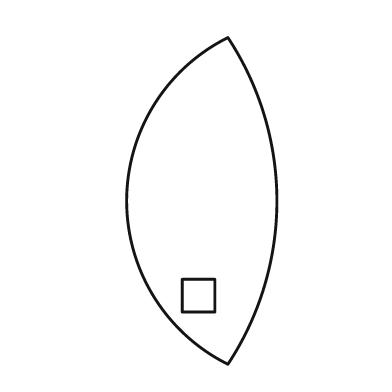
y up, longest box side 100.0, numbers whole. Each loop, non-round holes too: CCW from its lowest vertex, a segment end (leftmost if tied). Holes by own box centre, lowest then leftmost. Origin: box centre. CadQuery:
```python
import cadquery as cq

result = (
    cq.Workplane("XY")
    .moveTo(8.0, -50.0)
    .threePointArc((23.0, 0.0), (8.0, 50.0))
    .threePointArc((-23.0, 0.0), (8.0, -50.0))
    .close()
    .moveTo(-6.0, -34.0)
    .lineTo(4.0, -34.0)
    .lineTo(4.0, -24.0)
    .lineTo(-6.0, -24.0)
    .close()
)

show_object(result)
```